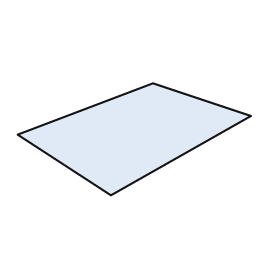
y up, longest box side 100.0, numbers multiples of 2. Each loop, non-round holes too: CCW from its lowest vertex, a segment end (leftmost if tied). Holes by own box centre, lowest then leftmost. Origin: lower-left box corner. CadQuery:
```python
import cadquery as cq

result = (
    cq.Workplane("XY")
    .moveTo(40.0, 0.0)
    .lineTo(100.0, 34.0)
    .lineTo(58.0, 48.0)
    .lineTo(0.0, 26.0)
    .close()
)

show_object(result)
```